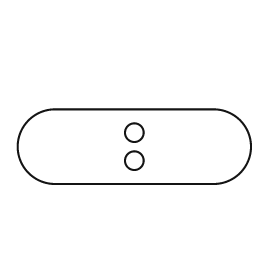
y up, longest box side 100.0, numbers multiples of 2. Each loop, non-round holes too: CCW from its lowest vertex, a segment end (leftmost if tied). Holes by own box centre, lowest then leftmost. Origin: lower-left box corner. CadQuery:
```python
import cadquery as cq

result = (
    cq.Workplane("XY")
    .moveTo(16.0, 0.0)
    .lineTo(84.0, 0.0)
    .threePointArc((100.0, 16.0), (84.0, 32.0))
    .lineTo(16.0, 32.0)
    .threePointArc((0.0, 16.0), (16.0, 0.0))
    .close()
    .moveTo(50.0, 10.0)
    .circle(4.0)
    .moveTo(50.0, 22.0)
    .circle(4.0)
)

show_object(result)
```